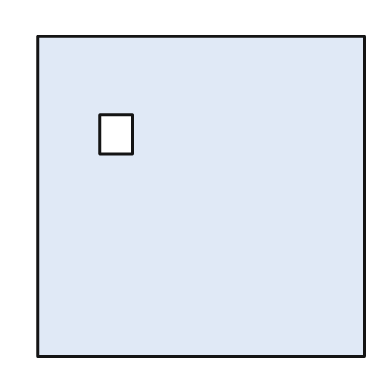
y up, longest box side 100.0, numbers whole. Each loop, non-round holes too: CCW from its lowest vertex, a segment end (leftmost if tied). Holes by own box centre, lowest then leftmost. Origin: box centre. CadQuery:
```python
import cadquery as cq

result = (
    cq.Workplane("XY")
    .moveTo(-50.0, -49.0)
    .lineTo(50.0, -49.0)
    .lineTo(50.0, 49.0)
    .lineTo(-50.0, 49.0)
    .close()
    .moveTo(-31.0, 13.0)
    .lineTo(-21.0, 13.0)
    .lineTo(-21.0, 25.0)
    .lineTo(-31.0, 25.0)
    .close()
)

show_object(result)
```